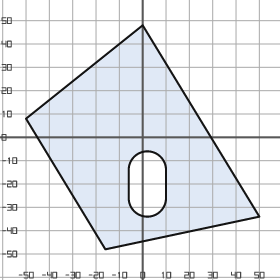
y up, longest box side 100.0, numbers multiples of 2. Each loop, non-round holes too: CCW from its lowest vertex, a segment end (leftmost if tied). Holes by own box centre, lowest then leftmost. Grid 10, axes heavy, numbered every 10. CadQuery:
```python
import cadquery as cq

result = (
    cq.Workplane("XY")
    .moveTo(-16.0, -48.0)
    .lineTo(50.0, -34.0)
    .lineTo(0.0, 48.0)
    .lineTo(-50.0, 8.0)
    .close()
    .moveTo(-6.0, -26.0)
    .threePointArc((2.0, -34.0), (10.0, -26.0))
    .lineTo(10.0, -14.0)
    .threePointArc((2.0, -6.0), (-6.0, -14.0))
    .close()
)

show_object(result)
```